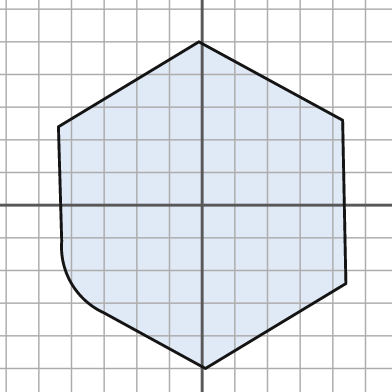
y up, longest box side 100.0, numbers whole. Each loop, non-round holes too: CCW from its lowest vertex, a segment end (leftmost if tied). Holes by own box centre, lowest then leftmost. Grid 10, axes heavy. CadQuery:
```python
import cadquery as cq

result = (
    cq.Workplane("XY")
    .moveTo(1.0, -50.0)
    .lineTo(44.0, -24.0)
    .lineTo(43.0, 26.0)
    .lineTo(-1.0, 50.0)
    .lineTo(-44.0, 24.0)
    .lineTo(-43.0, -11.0)
    .threePointArc((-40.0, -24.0), (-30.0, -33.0))
    .close()
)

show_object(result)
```